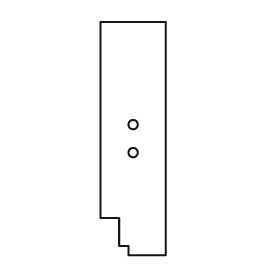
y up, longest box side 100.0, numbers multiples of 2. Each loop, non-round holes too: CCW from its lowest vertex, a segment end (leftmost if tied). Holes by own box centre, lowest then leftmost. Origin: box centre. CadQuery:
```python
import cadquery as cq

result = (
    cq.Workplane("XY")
    .moveTo(-2.0, -50.0)
    .lineTo(14.0, -50.0)
    .lineTo(14.0, 50.0)
    .lineTo(-14.0, 50.0)
    .lineTo(-14.0, -34.0)
    .lineTo(-6.0, -34.0)
    .lineTo(-6.0, -46.0)
    .lineTo(-2.0, -46.0)
    .close()
    .moveTo(0.0, -6.0)
    .circle(2.0)
    .moveTo(0.0, 6.0)
    .circle(2.0)
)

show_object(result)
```